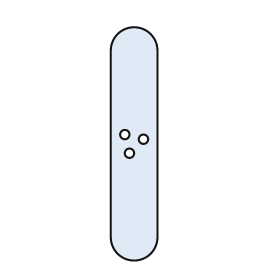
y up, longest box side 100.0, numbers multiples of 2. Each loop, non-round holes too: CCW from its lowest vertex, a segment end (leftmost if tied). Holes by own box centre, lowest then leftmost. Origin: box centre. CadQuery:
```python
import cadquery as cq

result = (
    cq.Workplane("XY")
    .moveTo(-10.0, -40.0)
    .threePointArc((0.0, -50.0), (10.0, -40.0))
    .lineTo(10.0, 40.0)
    .threePointArc((0.0, 50.0), (-10.0, 40.0))
    .close()
    .moveTo(-2.0, -4.0)
    .circle(2.0)
    .moveTo(4.0, 2.0)
    .circle(2.0)
    .moveTo(-4.0, 4.0)
    .circle(2.0)
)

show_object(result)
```